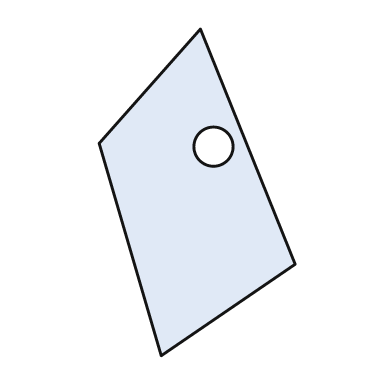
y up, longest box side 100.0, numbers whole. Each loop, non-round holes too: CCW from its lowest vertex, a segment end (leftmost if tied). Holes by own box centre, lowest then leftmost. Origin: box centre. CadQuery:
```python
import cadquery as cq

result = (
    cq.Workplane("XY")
    .moveTo(-11.0, -50.0)
    .lineTo(30.0, -22.0)
    .lineTo(1.0, 50.0)
    .lineTo(-30.0, 15.0)
    .close()
    .moveTo(5.0, 14.0)
    .circle(6.0)
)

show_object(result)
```